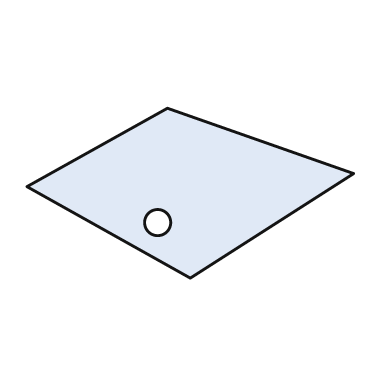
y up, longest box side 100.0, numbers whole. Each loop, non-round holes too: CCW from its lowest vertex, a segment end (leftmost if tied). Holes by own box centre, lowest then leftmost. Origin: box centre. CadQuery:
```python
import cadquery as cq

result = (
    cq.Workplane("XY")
    .moveTo(0.0, -26.0)
    .lineTo(50.0, 6.0)
    .lineTo(-7.0, 26.0)
    .lineTo(-50.0, 2.0)
    .close()
    .moveTo(-10.0, -9.0)
    .circle(4.0)
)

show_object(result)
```